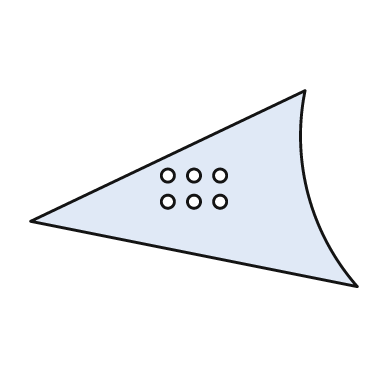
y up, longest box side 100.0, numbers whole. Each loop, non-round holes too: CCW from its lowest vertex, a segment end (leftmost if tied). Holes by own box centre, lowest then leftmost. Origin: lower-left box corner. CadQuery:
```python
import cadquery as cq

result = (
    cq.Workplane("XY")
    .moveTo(100.0, 0.0)
    .threePointArc((85.0, 28.0), (84.0, 60.0))
    .lineTo(0.0, 20.0)
    .close()
    .moveTo(42.0, 26.0)
    .circle(2.0)
    .moveTo(50.0, 26.0)
    .circle(2.0)
    .moveTo(58.0, 26.0)
    .circle(2.0)
    .moveTo(42.0, 34.0)
    .circle(2.0)
    .moveTo(50.0, 34.0)
    .circle(2.0)
    .moveTo(58.0, 34.0)
    .circle(2.0)
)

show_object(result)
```